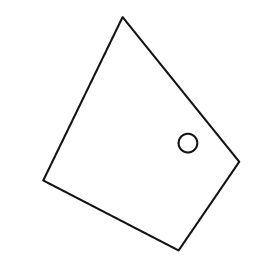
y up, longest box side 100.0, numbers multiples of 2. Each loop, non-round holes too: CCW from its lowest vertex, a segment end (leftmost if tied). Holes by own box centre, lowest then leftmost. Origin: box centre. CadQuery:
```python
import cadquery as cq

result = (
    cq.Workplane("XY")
    .moveTo(16.0, -50.0)
    .lineTo(42.0, -12.0)
    .lineTo(-8.0, 50.0)
    .lineTo(-42.0, -20.0)
    .close()
    .moveTo(20.0, -4.0)
    .circle(4.0)
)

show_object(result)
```